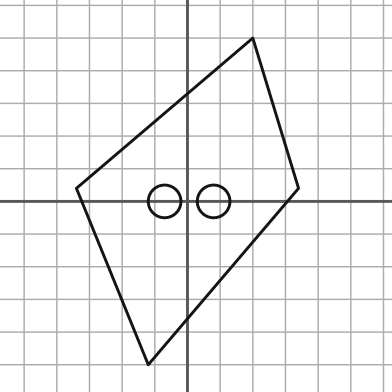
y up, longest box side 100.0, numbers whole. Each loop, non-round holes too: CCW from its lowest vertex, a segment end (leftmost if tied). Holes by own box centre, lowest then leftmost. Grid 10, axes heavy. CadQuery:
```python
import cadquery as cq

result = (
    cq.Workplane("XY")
    .moveTo(-12.0, -50.0)
    .lineTo(34.0, 4.0)
    .lineTo(20.0, 50.0)
    .lineTo(-34.0, 4.0)
    .close()
    .moveTo(-7.0, 0.0)
    .circle(5.0)
    .moveTo(8.0, 0.0)
    .circle(5.0)
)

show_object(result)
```